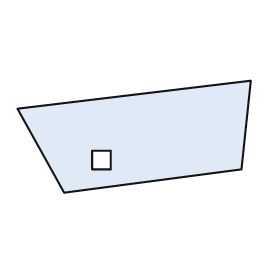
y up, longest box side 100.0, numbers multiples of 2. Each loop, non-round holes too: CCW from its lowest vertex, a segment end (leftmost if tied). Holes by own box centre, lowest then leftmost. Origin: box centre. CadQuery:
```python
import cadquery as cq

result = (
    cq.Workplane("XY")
    .moveTo(-30.0, -24.0)
    .lineTo(46.0, -14.0)
    .lineTo(50.0, 24.0)
    .lineTo(-50.0, 12.0)
    .close()
    .moveTo(-18.0, -14.0)
    .lineTo(-10.0, -14.0)
    .lineTo(-10.0, -6.0)
    .lineTo(-18.0, -6.0)
    .close()
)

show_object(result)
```